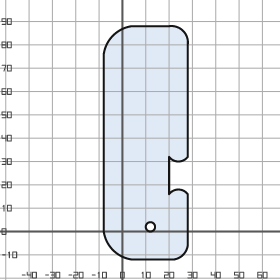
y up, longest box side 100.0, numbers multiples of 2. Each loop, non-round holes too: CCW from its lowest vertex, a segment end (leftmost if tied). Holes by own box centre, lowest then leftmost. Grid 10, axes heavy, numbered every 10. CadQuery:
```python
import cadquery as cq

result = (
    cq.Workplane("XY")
    .moveTo(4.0, -12.0)
    .lineTo(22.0, -12.0)
    .threePointArc((26.0, -10.0), (28.0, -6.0))
    .lineTo(28.0, 16.0)
    .threePointArc((24.0, 18.0), (20.0, 16.0))
    .lineTo(20.0, 32.0)
    .threePointArc((24.0, 30.0), (28.0, 32.0))
    .lineTo(28.0, 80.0)
    .threePointArc((26.0, 86.0), (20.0, 88.0))
    .lineTo(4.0, 88.0)
    .threePointArc((-4.0, 84.0), (-8.0, 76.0))
    .lineTo(-8.0, 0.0)
    .threePointArc((-4.0, -8.0), (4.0, -12.0))
    .close()
    .moveTo(12.0, 2.0)
    .circle(2.0)
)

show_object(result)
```